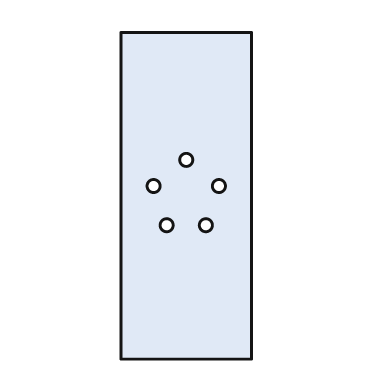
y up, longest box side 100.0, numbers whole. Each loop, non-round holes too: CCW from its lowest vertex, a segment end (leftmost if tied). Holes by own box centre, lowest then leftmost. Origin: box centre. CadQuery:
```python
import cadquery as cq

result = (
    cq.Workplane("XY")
    .moveTo(-20.0, -50.0)
    .lineTo(20.0, -50.0)
    .lineTo(20.0, 50.0)
    .lineTo(-20.0, 50.0)
    .close()
    .moveTo(-6.0, -9.0)
    .circle(2.0)
    .moveTo(6.0, -9.0)
    .circle(2.0)
    .moveTo(-10.0, 3.0)
    .circle(2.0)
    .moveTo(10.0, 3.0)
    .circle(2.0)
    .moveTo(0.0, 11.0)
    .circle(2.0)
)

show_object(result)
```